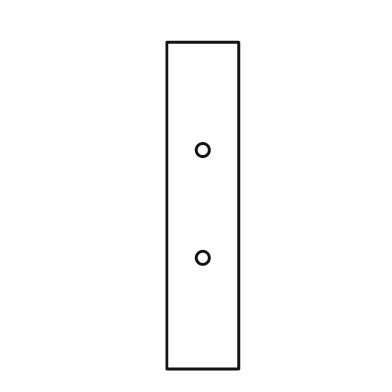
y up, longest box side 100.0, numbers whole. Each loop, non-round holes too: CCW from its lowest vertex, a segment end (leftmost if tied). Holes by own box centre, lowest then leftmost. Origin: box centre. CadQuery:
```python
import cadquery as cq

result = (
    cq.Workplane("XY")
    .moveTo(-11.0, -50.0)
    .lineTo(11.0, -50.0)
    .lineTo(11.0, 50.0)
    .lineTo(-11.0, 50.0)
    .close()
    .moveTo(0.0, -16.0)
    .circle(2.0)
    .moveTo(0.0, 17.0)
    .circle(2.0)
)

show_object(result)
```